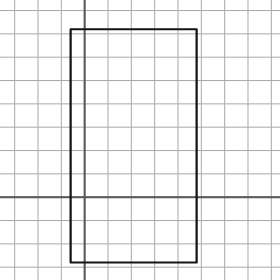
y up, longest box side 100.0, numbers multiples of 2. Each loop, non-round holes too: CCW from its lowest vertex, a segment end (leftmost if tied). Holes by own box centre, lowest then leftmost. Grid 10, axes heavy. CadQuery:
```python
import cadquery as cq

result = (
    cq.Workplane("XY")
    .moveTo(-6.0, -28.0)
    .lineTo(48.0, -28.0)
    .lineTo(48.0, 72.0)
    .lineTo(-6.0, 72.0)
    .close()
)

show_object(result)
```